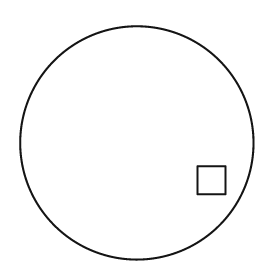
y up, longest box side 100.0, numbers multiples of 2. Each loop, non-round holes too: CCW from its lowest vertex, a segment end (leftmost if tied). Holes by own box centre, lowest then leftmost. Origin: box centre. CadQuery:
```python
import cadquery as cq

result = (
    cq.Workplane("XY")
    .moveTo(0.0, 0.0)
    .circle(50.0)
    .moveTo(26.0, -22.0)
    .lineTo(38.0, -22.0)
    .lineTo(38.0, -10.0)
    .lineTo(26.0, -10.0)
    .close()
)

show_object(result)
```